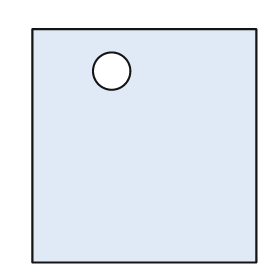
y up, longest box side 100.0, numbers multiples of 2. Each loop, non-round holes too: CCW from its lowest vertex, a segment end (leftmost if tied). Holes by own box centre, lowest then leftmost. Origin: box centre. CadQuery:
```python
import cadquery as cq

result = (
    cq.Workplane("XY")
    .moveTo(-48.0, -50.0)
    .lineTo(48.0, -50.0)
    .lineTo(48.0, 50.0)
    .lineTo(-48.0, 50.0)
    .close()
    .moveTo(-14.0, 32.0)
    .circle(8.0)
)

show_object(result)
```